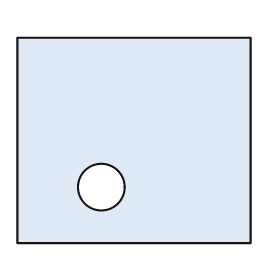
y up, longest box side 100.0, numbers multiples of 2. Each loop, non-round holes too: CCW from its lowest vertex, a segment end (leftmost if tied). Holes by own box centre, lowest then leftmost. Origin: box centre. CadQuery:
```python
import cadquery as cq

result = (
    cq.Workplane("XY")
    .moveTo(-50.0, -44.0)
    .lineTo(50.0, -44.0)
    .lineTo(50.0, 44.0)
    .lineTo(-50.0, 44.0)
    .close()
    .moveTo(-14.0, -20.0)
    .circle(10.0)
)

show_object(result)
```